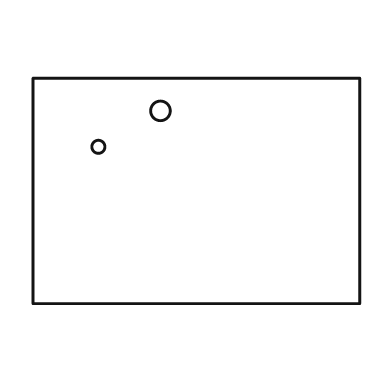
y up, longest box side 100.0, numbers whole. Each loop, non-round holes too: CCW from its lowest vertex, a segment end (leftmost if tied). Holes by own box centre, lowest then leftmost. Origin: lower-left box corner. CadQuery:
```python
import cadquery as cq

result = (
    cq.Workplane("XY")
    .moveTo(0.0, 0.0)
    .lineTo(100.0, 0.0)
    .lineTo(100.0, 69.0)
    .lineTo(0.0, 69.0)
    .close()
    .moveTo(20.0, 48.0)
    .circle(2.0)
    .moveTo(39.0, 59.0)
    .circle(3.0)
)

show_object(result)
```